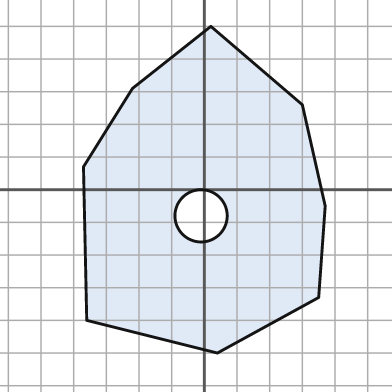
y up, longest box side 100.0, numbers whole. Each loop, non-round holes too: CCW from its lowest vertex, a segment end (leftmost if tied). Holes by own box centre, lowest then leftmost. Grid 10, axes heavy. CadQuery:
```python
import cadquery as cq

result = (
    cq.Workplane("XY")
    .moveTo(4.0, -50.0)
    .lineTo(35.0, -33.0)
    .lineTo(37.0, -5.0)
    .lineTo(30.0, 26.0)
    .lineTo(2.0, 50.0)
    .lineTo(-22.0, 31.0)
    .lineTo(-37.0, 7.0)
    .lineTo(-36.0, -40.0)
    .close()
    .moveTo(-1.0, -8.0)
    .circle(8.0)
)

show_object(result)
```